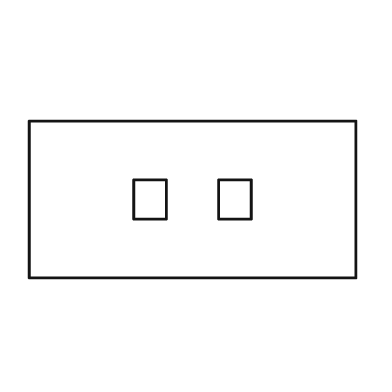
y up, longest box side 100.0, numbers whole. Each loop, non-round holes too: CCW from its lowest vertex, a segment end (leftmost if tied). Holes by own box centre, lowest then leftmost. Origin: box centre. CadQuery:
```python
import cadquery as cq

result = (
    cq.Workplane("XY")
    .moveTo(-50.0, -24.0)
    .lineTo(50.0, -24.0)
    .lineTo(50.0, 24.0)
    .lineTo(-50.0, 24.0)
    .close()
    .moveTo(-18.0, -6.0)
    .lineTo(-8.0, -6.0)
    .lineTo(-8.0, 6.0)
    .lineTo(-18.0, 6.0)
    .close()
    .moveTo(8.0, -6.0)
    .lineTo(18.0, -6.0)
    .lineTo(18.0, 6.0)
    .lineTo(8.0, 6.0)
    .close()
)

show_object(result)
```